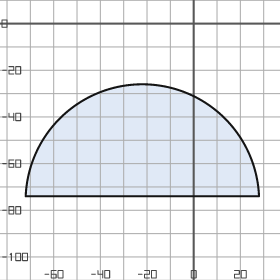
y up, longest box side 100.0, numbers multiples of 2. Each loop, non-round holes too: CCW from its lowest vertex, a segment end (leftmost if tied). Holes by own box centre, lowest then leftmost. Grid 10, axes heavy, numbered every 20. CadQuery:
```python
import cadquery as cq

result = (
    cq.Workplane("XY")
    .moveTo(-72.0, -74.0)
    .lineTo(28.0, -74.0)
    .threePointArc((-22.0, -26.0), (-72.0, -74.0))
    .close()
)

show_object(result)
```